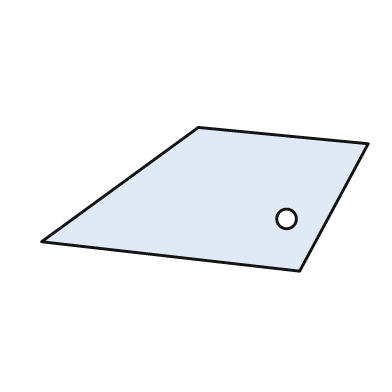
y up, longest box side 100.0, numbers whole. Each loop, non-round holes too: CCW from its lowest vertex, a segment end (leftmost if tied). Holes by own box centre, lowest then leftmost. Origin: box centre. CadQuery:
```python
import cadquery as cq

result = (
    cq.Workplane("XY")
    .moveTo(29.0, -22.0)
    .lineTo(50.0, 17.0)
    .lineTo(-2.0, 22.0)
    .lineTo(-50.0, -13.0)
    .close()
    .moveTo(25.0, -6.0)
    .circle(3.0)
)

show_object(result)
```